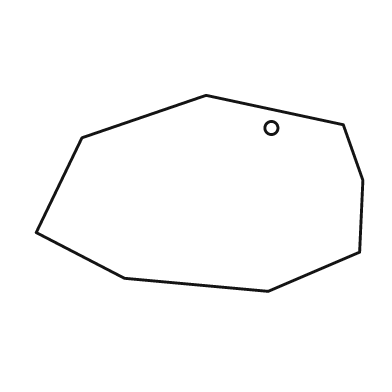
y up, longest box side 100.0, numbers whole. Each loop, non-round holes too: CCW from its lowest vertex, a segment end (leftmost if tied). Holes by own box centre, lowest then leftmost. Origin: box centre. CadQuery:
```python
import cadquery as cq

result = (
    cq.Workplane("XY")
    .moveTo(21.0, -30.0)
    .lineTo(49.0, -18.0)
    .lineTo(50.0, 4.0)
    .lineTo(44.0, 21.0)
    .lineTo(2.0, 30.0)
    .lineTo(-36.0, 17.0)
    .lineTo(-50.0, -12.0)
    .lineTo(-23.0, -26.0)
    .close()
    .moveTo(22.0, 20.0)
    .circle(2.0)
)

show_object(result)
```